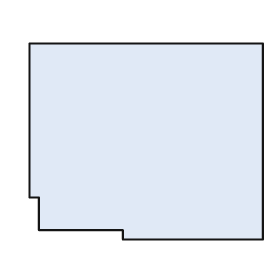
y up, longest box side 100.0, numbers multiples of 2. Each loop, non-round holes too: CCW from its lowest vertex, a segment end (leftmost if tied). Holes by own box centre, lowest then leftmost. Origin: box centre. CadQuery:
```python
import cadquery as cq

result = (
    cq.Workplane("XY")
    .moveTo(-10.0, -42.0)
    .lineTo(50.0, -42.0)
    .lineTo(50.0, 42.0)
    .lineTo(-50.0, 42.0)
    .lineTo(-50.0, -24.0)
    .lineTo(-46.0, -24.0)
    .lineTo(-46.0, -38.0)
    .lineTo(-10.0, -38.0)
    .close()
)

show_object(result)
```